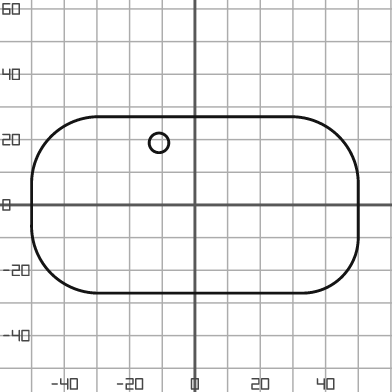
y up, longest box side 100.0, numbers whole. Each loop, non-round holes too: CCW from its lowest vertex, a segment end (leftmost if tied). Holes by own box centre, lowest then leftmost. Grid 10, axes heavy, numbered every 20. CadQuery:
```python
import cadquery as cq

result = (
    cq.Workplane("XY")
    .moveTo(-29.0, -27.0)
    .lineTo(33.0, -27.0)
    .threePointArc((45.0, -22.0), (50.0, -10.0))
    .lineTo(50.0, 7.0)
    .threePointArc((44.0, 21.0), (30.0, 27.0))
    .lineTo(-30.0, 27.0)
    .threePointArc((-44.0, 21.0), (-50.0, 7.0))
    .lineTo(-50.0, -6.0)
    .threePointArc((-44.0, -21.0), (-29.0, -27.0))
    .close()
    .moveTo(-11.0, 19.0)
    .circle(3.0)
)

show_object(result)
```